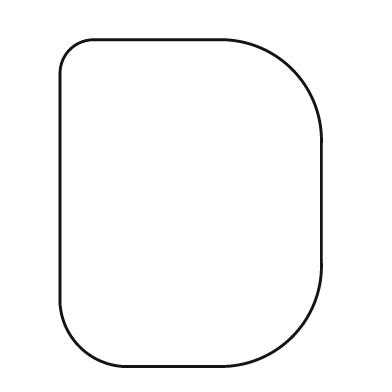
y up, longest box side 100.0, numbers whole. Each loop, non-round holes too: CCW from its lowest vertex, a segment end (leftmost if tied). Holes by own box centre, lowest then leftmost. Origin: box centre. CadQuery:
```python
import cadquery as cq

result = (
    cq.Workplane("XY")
    .moveTo(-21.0, -50.0)
    .lineTo(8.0, -50.0)
    .threePointArc((31.0, -41.0), (40.0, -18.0))
    .lineTo(40.0, 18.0)
    .threePointArc((31.0, 41.0), (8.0, 50.0))
    .lineTo(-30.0, 50.0)
    .threePointArc((-37.0, 47.0), (-40.0, 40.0))
    .lineTo(-40.0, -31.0)
    .threePointArc((-34.0, -44.0), (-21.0, -50.0))
    .close()
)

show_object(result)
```